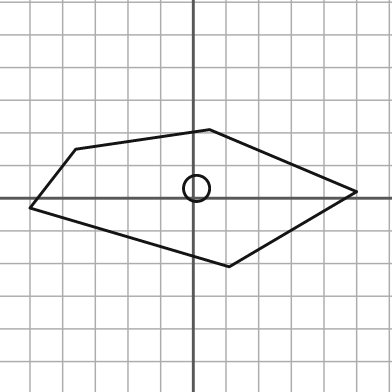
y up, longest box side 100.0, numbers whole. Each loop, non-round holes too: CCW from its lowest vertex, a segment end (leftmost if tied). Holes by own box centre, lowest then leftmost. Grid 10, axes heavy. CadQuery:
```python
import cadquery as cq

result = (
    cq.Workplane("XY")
    .moveTo(11.0, -21.0)
    .lineTo(50.0, 2.0)
    .lineTo(5.0, 21.0)
    .lineTo(-36.0, 15.0)
    .lineTo(-50.0, -3.0)
    .close()
    .moveTo(1.0, 3.0)
    .circle(4.0)
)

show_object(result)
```